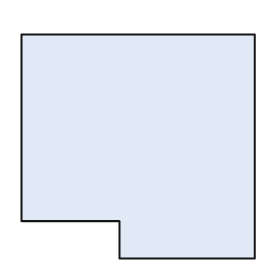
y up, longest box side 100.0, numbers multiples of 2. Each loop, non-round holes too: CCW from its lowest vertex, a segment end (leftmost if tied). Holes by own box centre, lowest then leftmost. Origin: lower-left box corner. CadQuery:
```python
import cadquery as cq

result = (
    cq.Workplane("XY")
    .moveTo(42.0, 0.0)
    .lineTo(100.0, 0.0)
    .lineTo(100.0, 96.0)
    .lineTo(0.0, 96.0)
    .lineTo(0.0, 16.0)
    .lineTo(42.0, 16.0)
    .close()
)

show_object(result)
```